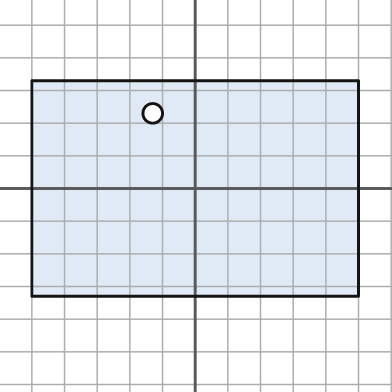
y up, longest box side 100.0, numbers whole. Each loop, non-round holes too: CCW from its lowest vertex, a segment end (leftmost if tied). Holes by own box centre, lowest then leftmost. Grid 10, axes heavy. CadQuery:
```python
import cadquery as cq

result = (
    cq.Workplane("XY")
    .moveTo(-50.0, -33.0)
    .lineTo(50.0, -33.0)
    .lineTo(50.0, 33.0)
    .lineTo(-50.0, 33.0)
    .close()
    .moveTo(-13.0, 23.0)
    .circle(3.0)
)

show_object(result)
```